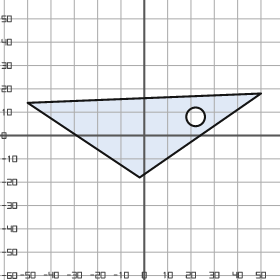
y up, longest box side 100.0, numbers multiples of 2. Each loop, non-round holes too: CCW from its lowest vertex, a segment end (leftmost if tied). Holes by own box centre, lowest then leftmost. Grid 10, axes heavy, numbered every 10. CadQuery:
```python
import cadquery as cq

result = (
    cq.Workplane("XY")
    .moveTo(-2.0, -18.0)
    .lineTo(50.0, 18.0)
    .lineTo(-50.0, 14.0)
    .close()
    .moveTo(22.0, 8.0)
    .circle(4.0)
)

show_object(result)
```